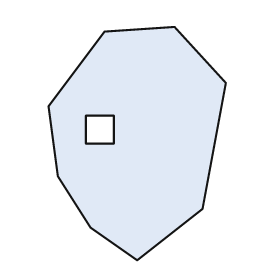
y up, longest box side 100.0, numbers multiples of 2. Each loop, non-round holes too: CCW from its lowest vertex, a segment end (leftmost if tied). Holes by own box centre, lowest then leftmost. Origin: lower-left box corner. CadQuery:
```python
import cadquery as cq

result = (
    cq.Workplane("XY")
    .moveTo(38.0, 0.0)
    .lineTo(66.0, 22.0)
    .lineTo(76.0, 76.0)
    .lineTo(54.0, 100.0)
    .lineTo(24.0, 98.0)
    .lineTo(0.0, 66.0)
    .lineTo(4.0, 36.0)
    .lineTo(18.0, 14.0)
    .close()
    .moveTo(16.0, 50.0)
    .lineTo(28.0, 50.0)
    .lineTo(28.0, 62.0)
    .lineTo(16.0, 62.0)
    .close()
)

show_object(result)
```